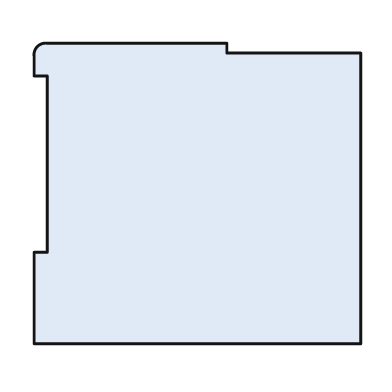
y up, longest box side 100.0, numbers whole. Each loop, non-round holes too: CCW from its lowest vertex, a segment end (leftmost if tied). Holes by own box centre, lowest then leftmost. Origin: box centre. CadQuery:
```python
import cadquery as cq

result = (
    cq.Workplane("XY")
    .moveTo(-50.0, -46.0)
    .lineTo(50.0, -46.0)
    .lineTo(50.0, 43.0)
    .lineTo(9.0, 43.0)
    .lineTo(9.0, 46.0)
    .lineTo(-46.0, 46.0)
    .threePointArc((-49.0, 45.0), (-50.0, 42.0))
    .lineTo(-50.0, 36.0)
    .lineTo(-46.0, 36.0)
    .lineTo(-46.0, -18.0)
    .lineTo(-50.0, -18.0)
    .close()
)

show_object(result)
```